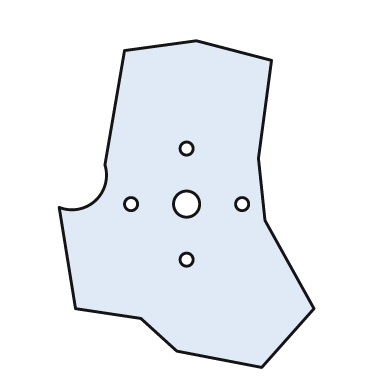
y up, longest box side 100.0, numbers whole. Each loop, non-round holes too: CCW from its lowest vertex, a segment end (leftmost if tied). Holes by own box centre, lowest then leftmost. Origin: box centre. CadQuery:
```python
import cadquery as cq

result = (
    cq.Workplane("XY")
    .moveTo(23.0, -50.0)
    .lineTo(39.0, -32.0)
    .lineTo(24.0, -5.0)
    .lineTo(22.0, 14.0)
    .lineTo(26.0, 44.0)
    .lineTo(3.0, 50.0)
    .lineTo(-19.0, 47.0)
    .lineTo(-25.0, 12.0)
    .threePointArc((-28.0, 1.0), (-39.0, -1.0))
    .lineTo(-34.0, -32.0)
    .lineTo(-14.0, -35.0)
    .lineTo(-3.0, -45.0)
    .close()
    .moveTo(0.0, -17.0)
    .circle(2.0)
    .moveTo(-17.0, 0.0)
    .circle(2.0)
    .moveTo(0.0, 0.0)
    .circle(4.0)
    .moveTo(17.0, 0.0)
    .circle(2.0)
    .moveTo(0.0, 17.0)
    .circle(2.0)
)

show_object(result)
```